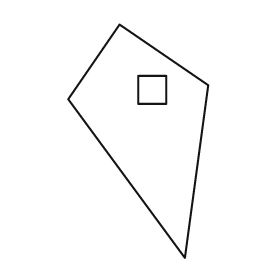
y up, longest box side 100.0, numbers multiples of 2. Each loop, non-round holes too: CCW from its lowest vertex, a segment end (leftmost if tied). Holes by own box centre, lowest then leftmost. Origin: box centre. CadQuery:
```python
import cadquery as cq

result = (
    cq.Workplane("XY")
    .moveTo(20.0, -50.0)
    .lineTo(30.0, 24.0)
    .lineTo(-8.0, 50.0)
    .lineTo(-30.0, 18.0)
    .close()
    .moveTo(0.0, 16.0)
    .lineTo(12.0, 16.0)
    .lineTo(12.0, 28.0)
    .lineTo(0.0, 28.0)
    .close()
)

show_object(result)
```